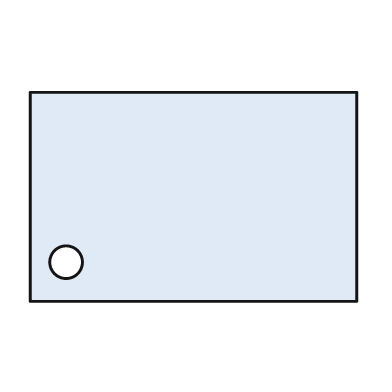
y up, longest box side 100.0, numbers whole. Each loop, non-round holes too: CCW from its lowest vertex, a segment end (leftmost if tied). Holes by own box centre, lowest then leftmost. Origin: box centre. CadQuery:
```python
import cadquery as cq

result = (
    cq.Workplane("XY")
    .moveTo(-50.0, -32.0)
    .lineTo(50.0, -32.0)
    .lineTo(50.0, 32.0)
    .lineTo(-50.0, 32.0)
    .close()
    .moveTo(-39.0, -20.0)
    .circle(5.0)
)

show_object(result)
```